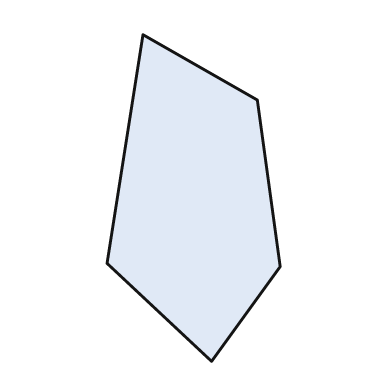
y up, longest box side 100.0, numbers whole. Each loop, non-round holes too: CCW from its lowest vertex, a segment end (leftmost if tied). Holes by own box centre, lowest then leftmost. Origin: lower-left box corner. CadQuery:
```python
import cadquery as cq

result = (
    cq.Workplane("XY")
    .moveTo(32.0, 0.0)
    .lineTo(53.0, 29.0)
    .lineTo(46.0, 80.0)
    .lineTo(11.0, 100.0)
    .lineTo(0.0, 30.0)
    .close()
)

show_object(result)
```